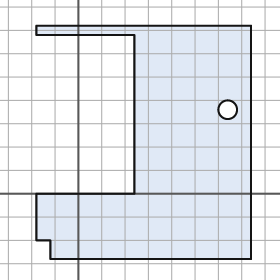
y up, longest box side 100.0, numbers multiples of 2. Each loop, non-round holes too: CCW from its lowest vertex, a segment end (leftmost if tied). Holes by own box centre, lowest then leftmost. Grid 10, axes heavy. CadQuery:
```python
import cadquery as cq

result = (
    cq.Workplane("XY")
    .moveTo(-12.0, -28.0)
    .lineTo(74.0, -28.0)
    .lineTo(74.0, 72.0)
    .lineTo(-18.0, 72.0)
    .lineTo(-18.0, 68.0)
    .lineTo(24.0, 68.0)
    .lineTo(24.0, 0.0)
    .lineTo(-18.0, 0.0)
    .lineTo(-18.0, -20.0)
    .lineTo(-12.0, -20.0)
    .close()
    .moveTo(64.0, 36.0)
    .circle(4.0)
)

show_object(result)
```